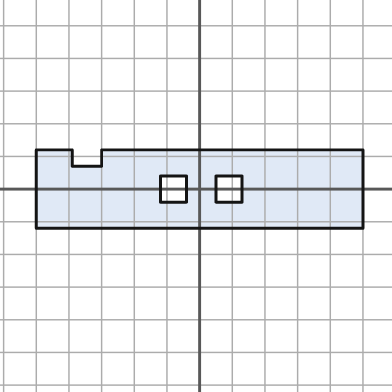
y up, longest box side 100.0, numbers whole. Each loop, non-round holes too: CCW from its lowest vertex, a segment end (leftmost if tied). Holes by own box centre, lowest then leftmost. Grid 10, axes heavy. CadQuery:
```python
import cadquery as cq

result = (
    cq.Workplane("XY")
    .moveTo(-50.0, -12.0)
    .lineTo(50.0, -12.0)
    .lineTo(50.0, 12.0)
    .lineTo(-30.0, 12.0)
    .lineTo(-30.0, 7.0)
    .lineTo(-39.0, 7.0)
    .lineTo(-39.0, 12.0)
    .lineTo(-50.0, 12.0)
    .close()
    .moveTo(-12.0, -4.0)
    .lineTo(-4.0, -4.0)
    .lineTo(-4.0, 4.0)
    .lineTo(-12.0, 4.0)
    .close()
    .moveTo(5.0, -4.0)
    .lineTo(13.0, -4.0)
    .lineTo(13.0, 4.0)
    .lineTo(5.0, 4.0)
    .close()
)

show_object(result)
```